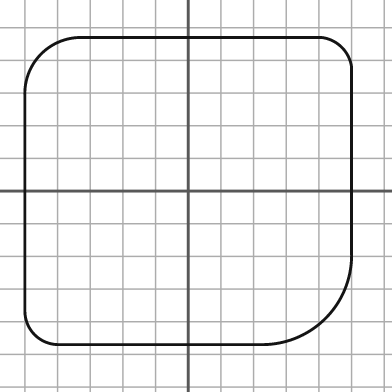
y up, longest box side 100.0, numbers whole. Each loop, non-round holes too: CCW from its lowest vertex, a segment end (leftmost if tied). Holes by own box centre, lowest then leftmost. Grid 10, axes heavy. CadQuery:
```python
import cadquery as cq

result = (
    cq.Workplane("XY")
    .moveTo(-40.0, -47.0)
    .lineTo(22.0, -47.0)
    .threePointArc((42.0, -39.0), (50.0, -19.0))
    .lineTo(50.0, 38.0)
    .threePointArc((47.0, 44.0), (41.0, 47.0))
    .lineTo(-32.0, 47.0)
    .threePointArc((-45.0, 42.0), (-50.0, 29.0))
    .lineTo(-50.0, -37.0)
    .threePointArc((-47.0, -44.0), (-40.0, -47.0))
    .close()
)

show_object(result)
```